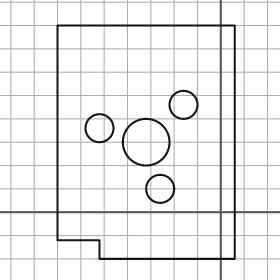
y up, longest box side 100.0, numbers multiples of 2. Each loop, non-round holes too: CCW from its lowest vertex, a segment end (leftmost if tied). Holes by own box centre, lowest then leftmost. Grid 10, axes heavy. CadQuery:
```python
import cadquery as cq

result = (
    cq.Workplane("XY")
    .moveTo(-52.0, -20.0)
    .lineTo(6.0, -20.0)
    .lineTo(6.0, 80.0)
    .lineTo(-70.0, 80.0)
    .lineTo(-70.0, -12.0)
    .lineTo(-52.0, -12.0)
    .close()
    .moveTo(-26.0, 10.0)
    .circle(6.0)
    .moveTo(-32.0, 30.0)
    .circle(10.0)
    .moveTo(-52.0, 36.0)
    .circle(6.0)
    .moveTo(-16.0, 46.0)
    .circle(6.0)
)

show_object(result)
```